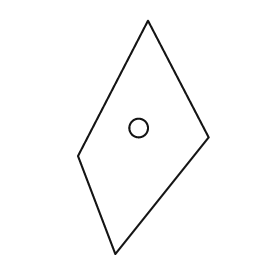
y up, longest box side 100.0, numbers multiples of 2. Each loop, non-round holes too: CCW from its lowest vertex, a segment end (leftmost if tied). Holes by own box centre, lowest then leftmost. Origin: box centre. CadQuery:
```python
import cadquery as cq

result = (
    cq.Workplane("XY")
    .moveTo(-12.0, -50.0)
    .lineTo(28.0, 0.0)
    .lineTo(2.0, 50.0)
    .lineTo(-28.0, -8.0)
    .close()
    .moveTo(-2.0, 4.0)
    .circle(4.0)
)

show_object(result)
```